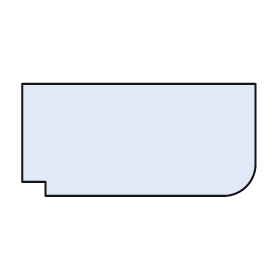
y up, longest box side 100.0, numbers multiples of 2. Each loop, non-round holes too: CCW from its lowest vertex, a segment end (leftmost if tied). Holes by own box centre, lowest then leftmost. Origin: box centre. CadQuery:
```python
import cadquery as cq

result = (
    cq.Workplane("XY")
    .moveTo(-40.0, -24.0)
    .lineTo(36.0, -24.0)
    .threePointArc((46.0, -20.0), (50.0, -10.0))
    .lineTo(50.0, 24.0)
    .lineTo(-50.0, 24.0)
    .lineTo(-50.0, -18.0)
    .lineTo(-40.0, -18.0)
    .close()
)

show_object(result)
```